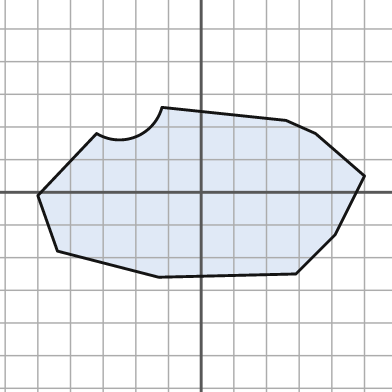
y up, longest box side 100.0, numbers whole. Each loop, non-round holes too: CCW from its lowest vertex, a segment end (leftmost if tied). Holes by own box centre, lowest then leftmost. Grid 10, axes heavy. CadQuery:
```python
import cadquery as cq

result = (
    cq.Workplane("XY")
    .moveTo(-13.0, -26.0)
    .lineTo(29.0, -25.0)
    .lineTo(41.0, -13.0)
    .lineTo(50.0, 5.0)
    .lineTo(35.0, 18.0)
    .lineTo(26.0, 22.0)
    .lineTo(-12.0, 26.0)
    .threePointArc((-20.0, 17.0), (-32.0, 18.0))
    .lineTo(-50.0, -1.0)
    .lineTo(-44.0, -18.0)
    .close()
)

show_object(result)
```